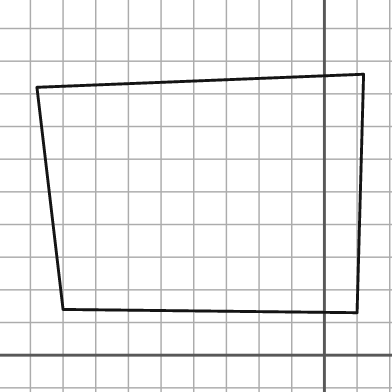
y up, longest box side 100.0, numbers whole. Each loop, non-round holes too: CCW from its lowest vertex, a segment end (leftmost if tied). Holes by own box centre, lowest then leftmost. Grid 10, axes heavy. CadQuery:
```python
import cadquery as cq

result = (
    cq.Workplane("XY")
    .moveTo(10.0, 13.0)
    .lineTo(12.0, 86.0)
    .lineTo(-88.0, 82.0)
    .lineTo(-80.0, 14.0)
    .close()
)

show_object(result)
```